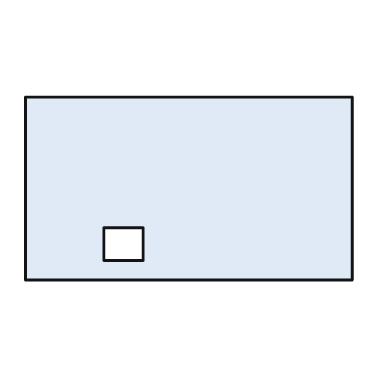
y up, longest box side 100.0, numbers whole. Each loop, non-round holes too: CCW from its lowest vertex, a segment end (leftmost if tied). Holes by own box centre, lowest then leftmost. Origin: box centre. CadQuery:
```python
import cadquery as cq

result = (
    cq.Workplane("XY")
    .moveTo(-50.0, -28.0)
    .lineTo(50.0, -28.0)
    .lineTo(50.0, 28.0)
    .lineTo(-50.0, 28.0)
    .close()
    .moveTo(-26.0, -22.0)
    .lineTo(-14.0, -22.0)
    .lineTo(-14.0, -12.0)
    .lineTo(-26.0, -12.0)
    .close()
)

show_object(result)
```